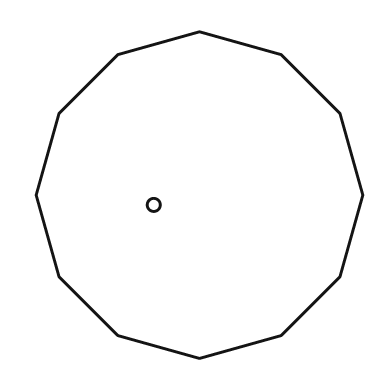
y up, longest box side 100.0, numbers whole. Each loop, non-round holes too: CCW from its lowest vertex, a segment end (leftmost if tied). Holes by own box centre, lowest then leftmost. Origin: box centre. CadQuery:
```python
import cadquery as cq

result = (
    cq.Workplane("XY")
    .moveTo(0.0, -50.0)
    .lineTo(25.0, -43.0)
    .lineTo(43.0, -25.0)
    .lineTo(50.0, 0.0)
    .lineTo(43.0, 25.0)
    .lineTo(25.0, 43.0)
    .lineTo(0.0, 50.0)
    .lineTo(-25.0, 43.0)
    .lineTo(-43.0, 25.0)
    .lineTo(-50.0, 0.0)
    .lineTo(-43.0, -25.0)
    .lineTo(-25.0, -43.0)
    .close()
    .moveTo(-14.0, -3.0)
    .circle(2.0)
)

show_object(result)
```